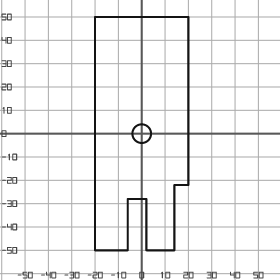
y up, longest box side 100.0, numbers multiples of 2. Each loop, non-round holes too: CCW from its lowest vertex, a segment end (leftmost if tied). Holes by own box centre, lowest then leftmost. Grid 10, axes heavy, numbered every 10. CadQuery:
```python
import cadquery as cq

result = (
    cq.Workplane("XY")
    .moveTo(-20.0, -50.0)
    .lineTo(-6.0, -50.0)
    .lineTo(-6.0, -28.0)
    .lineTo(2.0, -28.0)
    .lineTo(2.0, -50.0)
    .lineTo(14.0, -50.0)
    .lineTo(14.0, -22.0)
    .lineTo(20.0, -22.0)
    .lineTo(20.0, 50.0)
    .lineTo(-20.0, 50.0)
    .close()
    .moveTo(0.0, 0.0)
    .circle(4.0)
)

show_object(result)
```